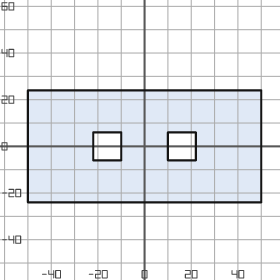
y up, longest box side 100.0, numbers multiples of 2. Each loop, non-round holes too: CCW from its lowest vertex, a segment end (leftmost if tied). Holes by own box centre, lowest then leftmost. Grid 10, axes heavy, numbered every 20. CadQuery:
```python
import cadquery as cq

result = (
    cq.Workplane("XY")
    .moveTo(-50.0, -24.0)
    .lineTo(50.0, -24.0)
    .lineTo(50.0, 24.0)
    .lineTo(-50.0, 24.0)
    .close()
    .moveTo(-22.0, -6.0)
    .lineTo(-10.0, -6.0)
    .lineTo(-10.0, 6.0)
    .lineTo(-22.0, 6.0)
    .close()
    .moveTo(10.0, -6.0)
    .lineTo(22.0, -6.0)
    .lineTo(22.0, 6.0)
    .lineTo(10.0, 6.0)
    .close()
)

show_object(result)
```